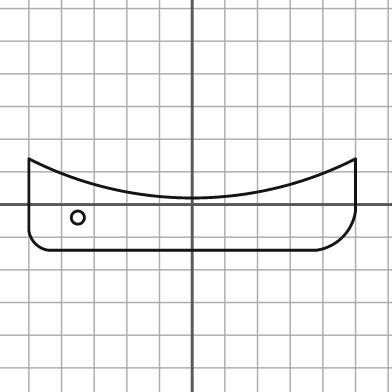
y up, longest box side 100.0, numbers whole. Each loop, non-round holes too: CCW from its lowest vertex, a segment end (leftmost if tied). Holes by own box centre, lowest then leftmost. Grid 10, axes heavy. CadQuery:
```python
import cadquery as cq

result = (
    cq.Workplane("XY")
    .moveTo(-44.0, -14.0)
    .lineTo(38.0, -14.0)
    .threePointArc((46.0, -10.0), (50.0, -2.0))
    .lineTo(50.0, 14.0)
    .threePointArc((0.0, 2.0), (-50.0, 14.0))
    .lineTo(-50.0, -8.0)
    .threePointArc((-48.0, -12.0), (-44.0, -14.0))
    .close()
    .moveTo(-35.0, -4.0)
    .circle(2.0)
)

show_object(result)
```